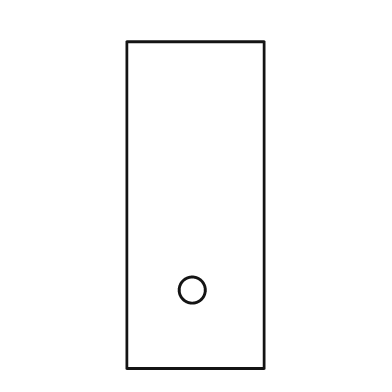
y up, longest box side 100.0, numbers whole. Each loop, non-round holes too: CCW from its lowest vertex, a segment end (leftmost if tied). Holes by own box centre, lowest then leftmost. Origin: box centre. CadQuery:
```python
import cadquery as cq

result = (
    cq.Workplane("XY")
    .moveTo(-21.0, -50.0)
    .lineTo(21.0, -50.0)
    .lineTo(21.0, 50.0)
    .lineTo(-21.0, 50.0)
    .close()
    .moveTo(-1.0, -26.0)
    .circle(4.0)
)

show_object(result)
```